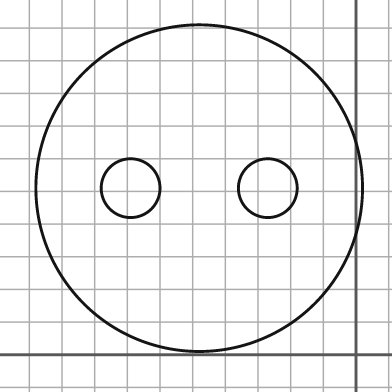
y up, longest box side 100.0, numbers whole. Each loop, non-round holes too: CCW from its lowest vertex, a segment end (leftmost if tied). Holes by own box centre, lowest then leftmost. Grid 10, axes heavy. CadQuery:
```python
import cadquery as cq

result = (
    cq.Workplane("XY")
    .moveTo(-48.0, 51.0)
    .circle(50.0)
    .moveTo(-69.0, 51.0)
    .circle(9.0)
    .moveTo(-27.0, 51.0)
    .circle(9.0)
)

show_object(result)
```